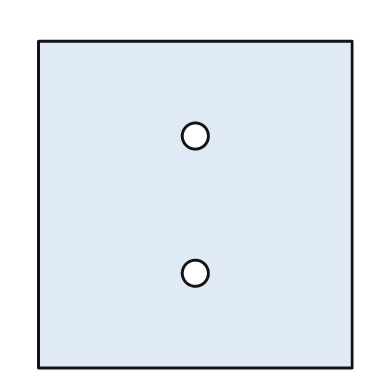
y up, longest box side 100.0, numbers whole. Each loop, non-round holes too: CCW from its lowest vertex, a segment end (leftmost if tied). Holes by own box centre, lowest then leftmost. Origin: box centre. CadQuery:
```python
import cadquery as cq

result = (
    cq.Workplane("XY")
    .moveTo(-48.0, -50.0)
    .lineTo(48.0, -50.0)
    .lineTo(48.0, 50.0)
    .lineTo(-48.0, 50.0)
    .close()
    .moveTo(0.0, -21.0)
    .circle(4.0)
    .moveTo(0.0, 21.0)
    .circle(4.0)
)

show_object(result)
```